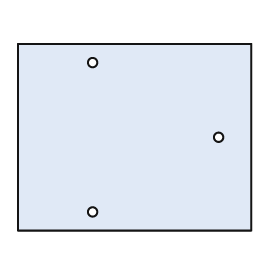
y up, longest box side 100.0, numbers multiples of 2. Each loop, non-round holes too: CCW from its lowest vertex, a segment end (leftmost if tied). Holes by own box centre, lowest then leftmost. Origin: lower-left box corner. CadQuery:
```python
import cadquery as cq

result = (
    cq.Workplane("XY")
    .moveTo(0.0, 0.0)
    .lineTo(100.0, 0.0)
    .lineTo(100.0, 80.0)
    .lineTo(0.0, 80.0)
    .close()
    .moveTo(32.0, 8.0)
    .circle(2.0)
    .moveTo(86.0, 40.0)
    .circle(2.0)
    .moveTo(32.0, 72.0)
    .circle(2.0)
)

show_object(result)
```